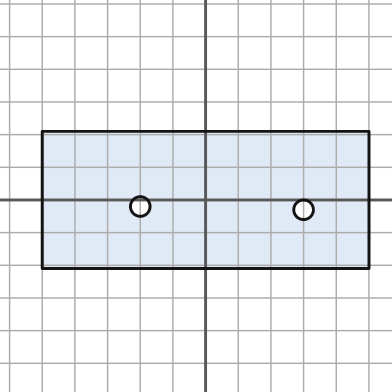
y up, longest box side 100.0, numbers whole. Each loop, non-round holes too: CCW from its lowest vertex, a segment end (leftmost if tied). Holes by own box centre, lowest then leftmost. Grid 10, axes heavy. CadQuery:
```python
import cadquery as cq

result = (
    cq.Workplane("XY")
    .moveTo(-50.0, -21.0)
    .lineTo(50.0, -21.0)
    .lineTo(50.0, 21.0)
    .lineTo(-50.0, 21.0)
    .close()
    .moveTo(30.0, -3.0)
    .circle(3.0)
    .moveTo(-20.0, -2.0)
    .circle(3.0)
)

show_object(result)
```